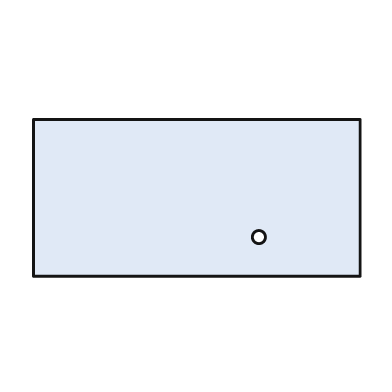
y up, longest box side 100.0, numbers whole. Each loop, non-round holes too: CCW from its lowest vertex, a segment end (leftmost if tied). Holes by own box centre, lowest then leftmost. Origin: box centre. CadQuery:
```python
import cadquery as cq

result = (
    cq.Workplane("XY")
    .moveTo(-50.0, -24.0)
    .lineTo(50.0, -24.0)
    .lineTo(50.0, 24.0)
    .lineTo(-50.0, 24.0)
    .close()
    .moveTo(19.0, -12.0)
    .circle(2.0)
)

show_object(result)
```